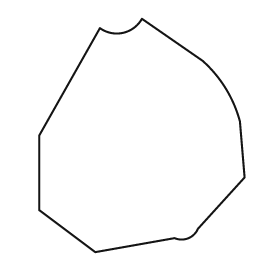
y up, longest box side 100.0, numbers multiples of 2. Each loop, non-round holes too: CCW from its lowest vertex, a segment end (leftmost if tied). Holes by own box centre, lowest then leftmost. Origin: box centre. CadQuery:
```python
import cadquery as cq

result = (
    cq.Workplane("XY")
    .moveTo(-20.0, -50.0)
    .lineTo(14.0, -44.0)
    .threePointArc((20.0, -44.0), (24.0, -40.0))
    .lineTo(44.0, -18.0)
    .lineTo(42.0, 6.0)
    .threePointArc((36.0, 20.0), (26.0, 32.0))
    .lineTo(0.0, 50.0)
    .threePointArc((-8.0, 44.0), (-18.0, 46.0))
    .lineTo(-44.0, 0.0)
    .lineTo(-44.0, -32.0)
    .close()
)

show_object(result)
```